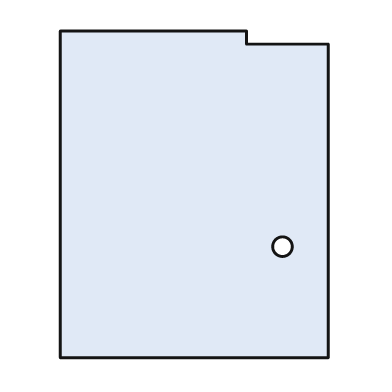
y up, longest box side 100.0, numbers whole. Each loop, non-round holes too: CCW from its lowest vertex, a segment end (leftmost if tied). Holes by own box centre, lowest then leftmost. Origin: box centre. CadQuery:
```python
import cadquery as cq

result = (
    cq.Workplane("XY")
    .moveTo(-41.0, -50.0)
    .lineTo(41.0, -50.0)
    .lineTo(41.0, 46.0)
    .lineTo(16.0, 46.0)
    .lineTo(16.0, 50.0)
    .lineTo(-41.0, 50.0)
    .close()
    .moveTo(27.0, -16.0)
    .circle(3.0)
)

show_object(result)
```